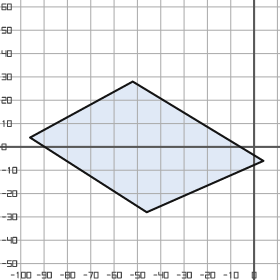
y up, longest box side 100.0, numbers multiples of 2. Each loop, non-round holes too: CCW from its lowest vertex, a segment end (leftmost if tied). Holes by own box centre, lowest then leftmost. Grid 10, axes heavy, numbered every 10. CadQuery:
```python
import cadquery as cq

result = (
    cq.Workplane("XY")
    .moveTo(-46.0, -28.0)
    .lineTo(4.0, -6.0)
    .lineTo(-52.0, 28.0)
    .lineTo(-96.0, 4.0)
    .close()
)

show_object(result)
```